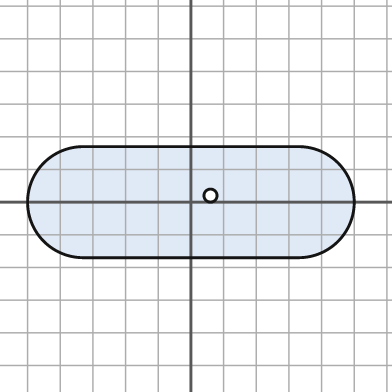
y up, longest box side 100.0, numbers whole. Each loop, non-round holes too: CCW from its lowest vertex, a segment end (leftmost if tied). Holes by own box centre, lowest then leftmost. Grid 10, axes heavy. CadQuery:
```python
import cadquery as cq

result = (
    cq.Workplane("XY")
    .moveTo(-33.0, -17.0)
    .lineTo(33.0, -17.0)
    .threePointArc((50.0, 0.0), (33.0, 17.0))
    .lineTo(-33.0, 17.0)
    .threePointArc((-50.0, 0.0), (-33.0, -17.0))
    .close()
    .moveTo(6.0, 2.0)
    .circle(2.0)
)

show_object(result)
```